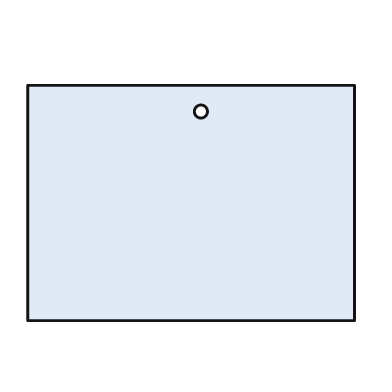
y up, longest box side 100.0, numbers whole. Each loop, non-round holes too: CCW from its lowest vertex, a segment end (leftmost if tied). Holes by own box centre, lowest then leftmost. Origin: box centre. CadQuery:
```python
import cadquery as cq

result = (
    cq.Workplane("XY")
    .moveTo(-50.0, -36.0)
    .lineTo(50.0, -36.0)
    .lineTo(50.0, 36.0)
    .lineTo(-50.0, 36.0)
    .close()
    .moveTo(3.0, 28.0)
    .circle(2.0)
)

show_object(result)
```